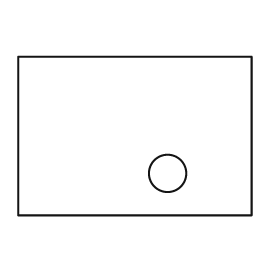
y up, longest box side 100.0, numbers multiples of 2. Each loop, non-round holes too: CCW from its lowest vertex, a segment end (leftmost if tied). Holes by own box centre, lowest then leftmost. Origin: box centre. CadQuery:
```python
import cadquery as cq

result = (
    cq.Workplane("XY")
    .moveTo(-50.0, -34.0)
    .lineTo(50.0, -34.0)
    .lineTo(50.0, 34.0)
    .lineTo(-50.0, 34.0)
    .close()
    .moveTo(14.0, -16.0)
    .circle(8.0)
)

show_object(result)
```